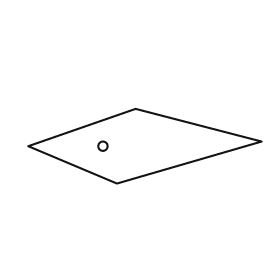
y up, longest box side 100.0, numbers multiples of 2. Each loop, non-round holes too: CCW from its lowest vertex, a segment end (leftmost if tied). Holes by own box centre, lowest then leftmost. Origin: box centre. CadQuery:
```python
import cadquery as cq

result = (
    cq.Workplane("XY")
    .moveTo(-12.0, -16.0)
    .lineTo(50.0, 2.0)
    .lineTo(-4.0, 16.0)
    .lineTo(-50.0, 0.0)
    .close()
    .moveTo(-18.0, 0.0)
    .circle(2.0)
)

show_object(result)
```